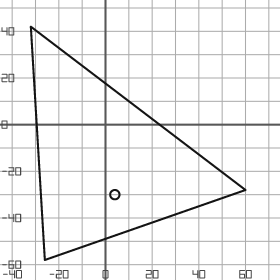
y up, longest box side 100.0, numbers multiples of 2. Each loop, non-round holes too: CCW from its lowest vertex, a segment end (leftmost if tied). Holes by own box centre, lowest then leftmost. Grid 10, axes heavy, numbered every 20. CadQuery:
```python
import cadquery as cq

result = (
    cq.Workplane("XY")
    .moveTo(-26.0, -58.0)
    .lineTo(60.0, -28.0)
    .lineTo(-32.0, 42.0)
    .close()
    .moveTo(4.0, -30.0)
    .circle(2.0)
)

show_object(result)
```